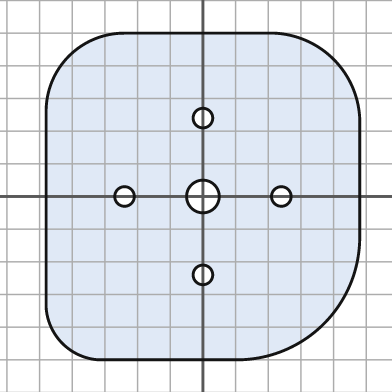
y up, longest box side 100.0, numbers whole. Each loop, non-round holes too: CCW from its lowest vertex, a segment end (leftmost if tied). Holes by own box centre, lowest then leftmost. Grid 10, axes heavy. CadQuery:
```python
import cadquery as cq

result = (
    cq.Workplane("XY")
    .moveTo(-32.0, -50.0)
    .lineTo(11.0, -50.0)
    .threePointArc((37.0, -39.0), (48.0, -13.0))
    .lineTo(48.0, 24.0)
    .threePointArc((40.0, 42.0), (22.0, 50.0))
    .lineTo(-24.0, 50.0)
    .threePointArc((-41.0, 43.0), (-48.0, 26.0))
    .lineTo(-48.0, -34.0)
    .threePointArc((-43.0, -45.0), (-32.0, -50.0))
    .close()
    .moveTo(0.0, -24.0)
    .circle(3.0)
    .moveTo(-24.0, 0.0)
    .circle(3.0)
    .moveTo(0.0, 0.0)
    .circle(5.0)
    .moveTo(24.0, 0.0)
    .circle(3.0)
    .moveTo(0.0, 24.0)
    .circle(3.0)
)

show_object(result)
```